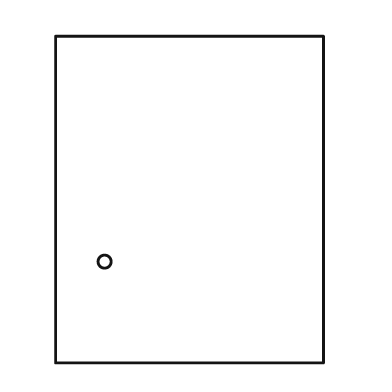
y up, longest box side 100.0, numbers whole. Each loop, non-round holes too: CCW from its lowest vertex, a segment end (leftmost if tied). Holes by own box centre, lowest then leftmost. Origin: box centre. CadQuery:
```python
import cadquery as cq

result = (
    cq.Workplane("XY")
    .moveTo(-41.0, -50.0)
    .lineTo(41.0, -50.0)
    .lineTo(41.0, 50.0)
    .lineTo(-41.0, 50.0)
    .close()
    .moveTo(-26.0, -19.0)
    .circle(2.0)
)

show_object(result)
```